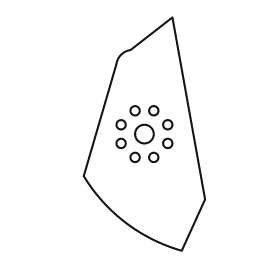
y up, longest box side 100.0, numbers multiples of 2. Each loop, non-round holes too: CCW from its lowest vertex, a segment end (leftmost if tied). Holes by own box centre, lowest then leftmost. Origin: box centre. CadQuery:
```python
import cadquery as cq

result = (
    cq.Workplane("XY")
    .moveTo(16.0, -50.0)
    .lineTo(26.0, -28.0)
    .lineTo(12.0, 50.0)
    .lineTo(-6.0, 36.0)
    .threePointArc((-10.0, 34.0), (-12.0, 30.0))
    .lineTo(-26.0, -18.0)
    .threePointArc((-8.0, -38.0), (16.0, -50.0))
    .close()
    .moveTo(-4.0, -10.0)
    .circle(2.0)
    .moveTo(4.0, -10.0)
    .circle(2.0)
    .moveTo(-10.0, -4.0)
    .circle(2.0)
    .moveTo(10.0, -4.0)
    .circle(2.0)
    .moveTo(0.0, 0.0)
    .circle(4.0)
    .moveTo(-10.0, 4.0)
    .circle(2.0)
    .moveTo(10.0, 4.0)
    .circle(2.0)
    .moveTo(-4.0, 10.0)
    .circle(2.0)
    .moveTo(4.0, 10.0)
    .circle(2.0)
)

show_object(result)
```